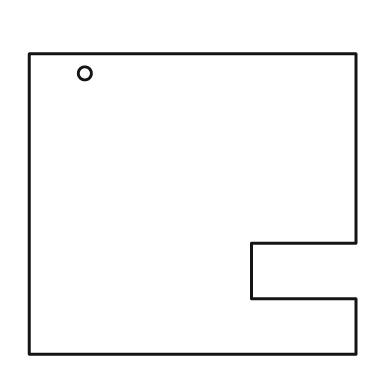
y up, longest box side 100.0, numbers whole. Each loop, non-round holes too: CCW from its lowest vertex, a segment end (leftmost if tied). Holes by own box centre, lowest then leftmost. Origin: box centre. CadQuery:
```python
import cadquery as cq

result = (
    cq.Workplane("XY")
    .moveTo(-50.0, -46.0)
    .lineTo(50.0, -46.0)
    .lineTo(50.0, -29.0)
    .lineTo(18.0, -29.0)
    .lineTo(18.0, -12.0)
    .lineTo(50.0, -12.0)
    .lineTo(50.0, 46.0)
    .lineTo(-50.0, 46.0)
    .close()
    .moveTo(-33.0, 40.0)
    .circle(2.0)
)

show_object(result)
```